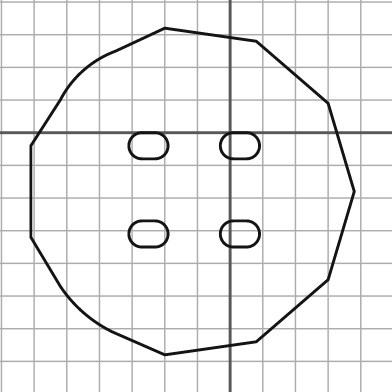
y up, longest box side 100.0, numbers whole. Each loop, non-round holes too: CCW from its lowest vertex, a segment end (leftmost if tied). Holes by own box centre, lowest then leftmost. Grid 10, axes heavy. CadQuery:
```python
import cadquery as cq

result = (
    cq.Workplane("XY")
    .moveTo(-20.0, -68.0)
    .lineTo(8.0, -64.0)
    .lineTo(30.0, -45.0)
    .lineTo(38.0, -18.0)
    .lineTo(30.0, 9.0)
    .lineTo(8.0, 28.0)
    .lineTo(-20.0, 32.0)
    .lineTo(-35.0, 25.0)
    .threePointArc((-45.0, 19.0), (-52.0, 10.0))
    .lineTo(-61.0, -4.0)
    .lineTo(-61.0, -32.0)
    .lineTo(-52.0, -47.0)
    .threePointArc((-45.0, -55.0), (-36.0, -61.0))
    .close()
    .moveTo(-27.0, -35.0)
    .lineTo(-23.0, -35.0)
    .threePointArc((-19.0, -31.0), (-23.0, -27.0))
    .lineTo(-27.0, -27.0)
    .threePointArc((-31.0, -31.0), (-27.0, -35.0))
    .close()
    .moveTo(1.0, -35.0)
    .lineTo(5.0, -35.0)
    .threePointArc((9.0, -31.0), (5.0, -27.0))
    .lineTo(1.0, -27.0)
    .threePointArc((-3.0, -31.0), (1.0, -35.0))
    .close()
    .moveTo(-27.0, -8.0)
    .lineTo(-23.0, -8.0)
    .threePointArc((-19.0, -4.0), (-23.0, 0.0))
    .lineTo(-27.0, 0.0)
    .threePointArc((-31.0, -4.0), (-27.0, -8.0))
    .close()
    .moveTo(1.0, -8.0)
    .lineTo(5.0, -8.0)
    .threePointArc((9.0, -4.0), (5.0, 0.0))
    .lineTo(1.0, 0.0)
    .threePointArc((-3.0, -4.0), (1.0, -8.0))
    .close()
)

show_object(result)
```